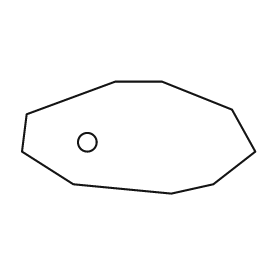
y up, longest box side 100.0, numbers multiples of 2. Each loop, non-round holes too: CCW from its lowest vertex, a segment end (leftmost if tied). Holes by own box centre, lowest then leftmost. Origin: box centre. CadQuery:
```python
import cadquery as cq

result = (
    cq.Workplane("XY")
    .moveTo(14.0, -24.0)
    .lineTo(32.0, -20.0)
    .lineTo(50.0, -6.0)
    .lineTo(40.0, 12.0)
    .lineTo(10.0, 24.0)
    .lineTo(-10.0, 24.0)
    .lineTo(-48.0, 10.0)
    .lineTo(-50.0, -6.0)
    .lineTo(-28.0, -20.0)
    .close()
    .moveTo(-22.0, -2.0)
    .circle(4.0)
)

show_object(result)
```